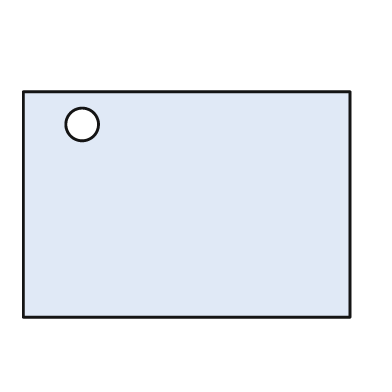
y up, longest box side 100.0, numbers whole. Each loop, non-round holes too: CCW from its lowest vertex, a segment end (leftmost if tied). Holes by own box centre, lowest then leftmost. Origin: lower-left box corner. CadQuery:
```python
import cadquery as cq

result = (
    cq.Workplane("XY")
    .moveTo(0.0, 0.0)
    .lineTo(100.0, 0.0)
    .lineTo(100.0, 69.0)
    .lineTo(0.0, 69.0)
    .close()
    .moveTo(18.0, 59.0)
    .circle(5.0)
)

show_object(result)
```